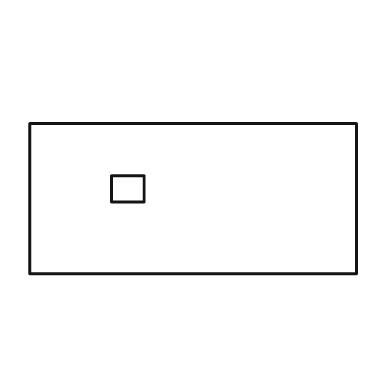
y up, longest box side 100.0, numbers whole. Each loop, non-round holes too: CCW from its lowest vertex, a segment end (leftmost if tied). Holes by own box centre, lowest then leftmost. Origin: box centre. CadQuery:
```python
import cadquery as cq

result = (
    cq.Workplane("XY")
    .moveTo(-50.0, -23.0)
    .lineTo(50.0, -23.0)
    .lineTo(50.0, 23.0)
    .lineTo(-50.0, 23.0)
    .close()
    .moveTo(-25.0, -1.0)
    .lineTo(-15.0, -1.0)
    .lineTo(-15.0, 7.0)
    .lineTo(-25.0, 7.0)
    .close()
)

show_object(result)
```